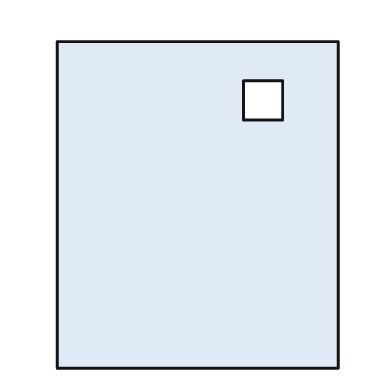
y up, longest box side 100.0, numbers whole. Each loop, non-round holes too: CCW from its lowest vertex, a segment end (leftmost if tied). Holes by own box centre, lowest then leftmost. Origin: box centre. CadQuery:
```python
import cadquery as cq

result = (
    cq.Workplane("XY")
    .moveTo(-43.0, -50.0)
    .lineTo(43.0, -50.0)
    .lineTo(43.0, 50.0)
    .lineTo(-43.0, 50.0)
    .close()
    .moveTo(14.0, 26.0)
    .lineTo(26.0, 26.0)
    .lineTo(26.0, 38.0)
    .lineTo(14.0, 38.0)
    .close()
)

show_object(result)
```